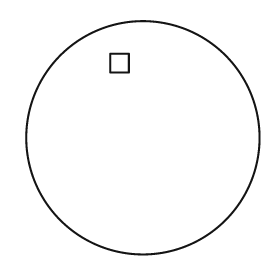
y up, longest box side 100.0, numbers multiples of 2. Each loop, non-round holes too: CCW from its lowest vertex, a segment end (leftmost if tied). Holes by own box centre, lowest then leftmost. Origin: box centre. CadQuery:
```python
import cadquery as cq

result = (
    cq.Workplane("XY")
    .moveTo(0.0, 0.0)
    .circle(50.0)
    .moveTo(-14.0, 28.0)
    .lineTo(-6.0, 28.0)
    .lineTo(-6.0, 36.0)
    .lineTo(-14.0, 36.0)
    .close()
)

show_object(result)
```